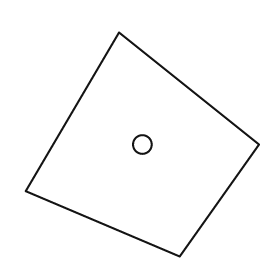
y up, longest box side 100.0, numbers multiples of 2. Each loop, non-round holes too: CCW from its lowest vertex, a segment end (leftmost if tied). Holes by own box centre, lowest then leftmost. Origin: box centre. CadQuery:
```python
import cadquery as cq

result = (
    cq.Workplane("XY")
    .moveTo(16.0, -48.0)
    .lineTo(50.0, 0.0)
    .lineTo(-10.0, 48.0)
    .lineTo(-50.0, -20.0)
    .close()
    .moveTo(0.0, 0.0)
    .circle(4.0)
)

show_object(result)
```